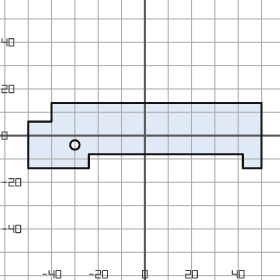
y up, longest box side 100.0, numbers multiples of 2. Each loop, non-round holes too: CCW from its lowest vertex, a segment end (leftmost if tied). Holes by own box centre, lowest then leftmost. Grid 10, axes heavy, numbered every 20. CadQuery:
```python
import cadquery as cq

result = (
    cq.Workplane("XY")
    .moveTo(-50.0, -14.0)
    .lineTo(-24.0, -14.0)
    .lineTo(-24.0, -8.0)
    .lineTo(42.0, -8.0)
    .lineTo(42.0, -14.0)
    .lineTo(50.0, -14.0)
    .lineTo(50.0, 14.0)
    .lineTo(-40.0, 14.0)
    .lineTo(-40.0, 6.0)
    .lineTo(-50.0, 6.0)
    .close()
    .moveTo(-30.0, -4.0)
    .circle(2.0)
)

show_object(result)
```